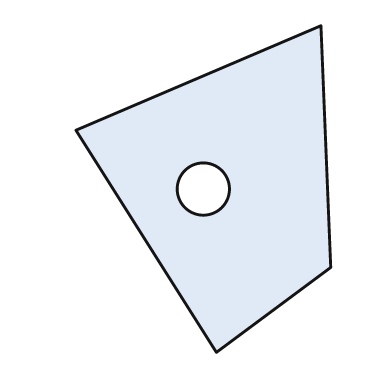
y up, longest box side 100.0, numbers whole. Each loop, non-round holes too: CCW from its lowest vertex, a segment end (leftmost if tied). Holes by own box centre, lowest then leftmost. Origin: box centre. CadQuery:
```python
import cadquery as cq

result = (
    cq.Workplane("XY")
    .moveTo(4.0, -50.0)
    .lineTo(39.0, -24.0)
    .lineTo(36.0, 50.0)
    .lineTo(-39.0, 18.0)
    .close()
    .moveTo(0.0, 0.0)
    .circle(8.0)
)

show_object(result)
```